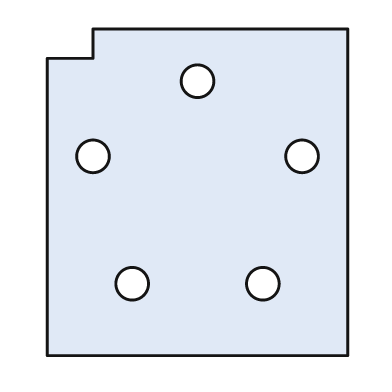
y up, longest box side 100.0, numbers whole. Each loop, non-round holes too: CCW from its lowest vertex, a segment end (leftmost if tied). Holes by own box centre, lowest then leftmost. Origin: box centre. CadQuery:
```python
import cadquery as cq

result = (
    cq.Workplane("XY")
    .moveTo(-46.0, -50.0)
    .lineTo(46.0, -50.0)
    .lineTo(46.0, 50.0)
    .lineTo(-32.0, 50.0)
    .lineTo(-32.0, 41.0)
    .lineTo(-46.0, 41.0)
    .close()
    .moveTo(-20.0, -28.0)
    .circle(5.0)
    .moveTo(20.0, -28.0)
    .circle(5.0)
    .moveTo(-32.0, 11.0)
    .circle(5.0)
    .moveTo(32.0, 11.0)
    .circle(5.0)
    .moveTo(0.0, 34.0)
    .circle(5.0)
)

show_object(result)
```